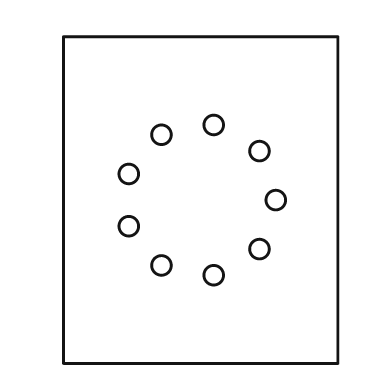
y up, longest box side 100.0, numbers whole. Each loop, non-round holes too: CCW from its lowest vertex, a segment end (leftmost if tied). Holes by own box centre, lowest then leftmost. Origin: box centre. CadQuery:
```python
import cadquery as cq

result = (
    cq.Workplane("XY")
    .moveTo(-42.0, -50.0)
    .lineTo(42.0, -50.0)
    .lineTo(42.0, 50.0)
    .lineTo(-42.0, 50.0)
    .close()
    .moveTo(4.0, -23.0)
    .circle(3.0)
    .moveTo(-12.0, -20.0)
    .circle(3.0)
    .moveTo(18.0, -15.0)
    .circle(3.0)
    .moveTo(-22.0, -8.0)
    .circle(3.0)
    .moveTo(23.0, 0.0)
    .circle(3.0)
    .moveTo(-22.0, 8.0)
    .circle(3.0)
    .moveTo(18.0, 15.0)
    .circle(3.0)
    .moveTo(-12.0, 20.0)
    .circle(3.0)
    .moveTo(4.0, 23.0)
    .circle(3.0)
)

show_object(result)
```